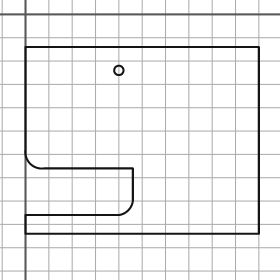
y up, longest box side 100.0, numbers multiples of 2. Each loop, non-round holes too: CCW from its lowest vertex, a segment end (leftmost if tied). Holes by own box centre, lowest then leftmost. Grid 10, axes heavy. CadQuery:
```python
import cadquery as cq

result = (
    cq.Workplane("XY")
    .moveTo(0.0, -94.0)
    .lineTo(100.0, -94.0)
    .lineTo(100.0, -14.0)
    .lineTo(0.0, -14.0)
    .lineTo(0.0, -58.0)
    .threePointArc((2.0, -64.0), (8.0, -66.0))
    .lineTo(46.0, -66.0)
    .lineTo(46.0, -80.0)
    .threePointArc((44.0, -84.0), (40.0, -86.0))
    .lineTo(0.0, -86.0)
    .close()
    .moveTo(40.0, -24.0)
    .circle(2.0)
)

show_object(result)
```